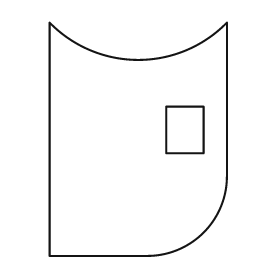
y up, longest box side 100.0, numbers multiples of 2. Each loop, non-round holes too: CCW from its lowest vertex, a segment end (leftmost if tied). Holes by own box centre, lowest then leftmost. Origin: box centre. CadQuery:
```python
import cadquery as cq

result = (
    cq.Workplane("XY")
    .moveTo(-38.0, -50.0)
    .lineTo(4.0, -50.0)
    .threePointArc((28.0, -40.0), (38.0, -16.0))
    .lineTo(38.0, 50.0)
    .threePointArc((0.0, 34.0), (-38.0, 50.0))
    .close()
    .moveTo(12.0, -6.0)
    .lineTo(28.0, -6.0)
    .lineTo(28.0, 14.0)
    .lineTo(12.0, 14.0)
    .close()
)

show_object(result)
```